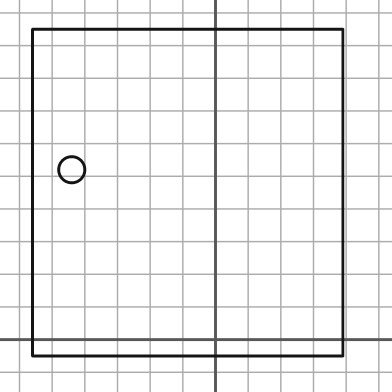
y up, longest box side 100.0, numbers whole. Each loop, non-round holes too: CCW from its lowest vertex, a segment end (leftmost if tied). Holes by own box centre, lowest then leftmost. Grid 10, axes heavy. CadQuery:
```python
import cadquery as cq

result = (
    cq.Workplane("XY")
    .moveTo(-56.0, -5.0)
    .lineTo(39.0, -5.0)
    .lineTo(39.0, 95.0)
    .lineTo(-56.0, 95.0)
    .close()
    .moveTo(-44.0, 52.0)
    .circle(4.0)
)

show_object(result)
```